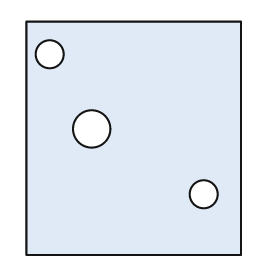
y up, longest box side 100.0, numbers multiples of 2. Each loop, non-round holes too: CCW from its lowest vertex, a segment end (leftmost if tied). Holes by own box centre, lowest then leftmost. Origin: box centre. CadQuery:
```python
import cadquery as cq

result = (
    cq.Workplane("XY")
    .moveTo(-46.0, -50.0)
    .lineTo(46.0, -50.0)
    .lineTo(46.0, 50.0)
    .lineTo(-46.0, 50.0)
    .close()
    .moveTo(30.0, -24.0)
    .circle(6.0)
    .moveTo(-18.0, 4.0)
    .circle(8.0)
    .moveTo(-36.0, 36.0)
    .circle(6.0)
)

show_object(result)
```